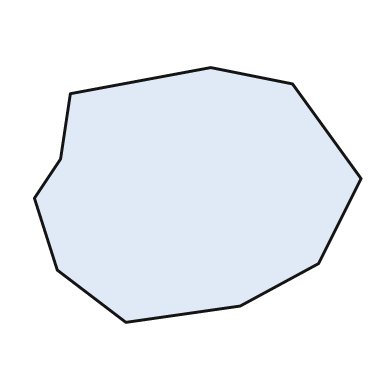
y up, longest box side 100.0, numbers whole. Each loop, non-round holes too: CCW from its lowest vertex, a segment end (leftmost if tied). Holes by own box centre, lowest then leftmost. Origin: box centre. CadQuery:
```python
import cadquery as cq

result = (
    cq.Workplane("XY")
    .moveTo(-22.0, -39.0)
    .lineTo(13.0, -34.0)
    .lineTo(37.0, -21.0)
    .lineTo(50.0, 5.0)
    .lineTo(29.0, 34.0)
    .lineTo(4.0, 39.0)
    .lineTo(-39.0, 31.0)
    .lineTo(-42.0, 11.0)
    .lineTo(-50.0, -1.0)
    .lineTo(-43.0, -23.0)
    .close()
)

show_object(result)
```